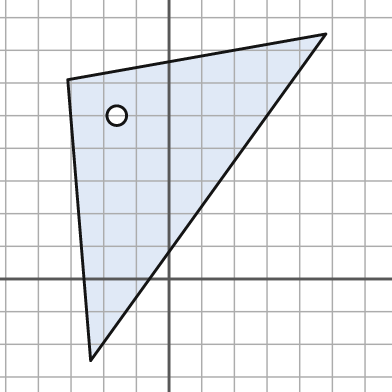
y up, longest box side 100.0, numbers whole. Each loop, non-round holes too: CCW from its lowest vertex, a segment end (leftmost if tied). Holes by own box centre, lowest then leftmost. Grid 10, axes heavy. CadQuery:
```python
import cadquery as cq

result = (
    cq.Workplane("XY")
    .moveTo(-24.0, -25.0)
    .lineTo(48.0, 75.0)
    .lineTo(-31.0, 61.0)
    .close()
    .moveTo(-16.0, 50.0)
    .circle(3.0)
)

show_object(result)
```